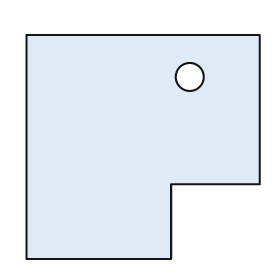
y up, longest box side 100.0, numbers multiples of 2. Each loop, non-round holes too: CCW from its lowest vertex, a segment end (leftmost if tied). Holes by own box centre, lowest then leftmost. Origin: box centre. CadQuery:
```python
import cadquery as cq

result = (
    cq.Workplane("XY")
    .moveTo(-50.0, -48.0)
    .lineTo(12.0, -48.0)
    .lineTo(12.0, -16.0)
    .lineTo(50.0, -16.0)
    .lineTo(50.0, 48.0)
    .lineTo(-50.0, 48.0)
    .close()
    .moveTo(20.0, 30.0)
    .circle(6.0)
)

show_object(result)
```